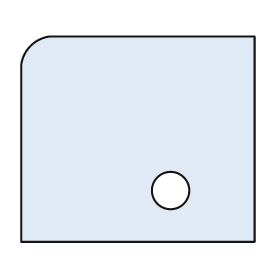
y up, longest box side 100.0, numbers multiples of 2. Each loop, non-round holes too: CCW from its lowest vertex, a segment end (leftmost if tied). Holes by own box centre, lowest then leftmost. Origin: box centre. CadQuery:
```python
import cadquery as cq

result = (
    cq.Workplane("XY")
    .moveTo(-50.0, -44.0)
    .lineTo(50.0, -44.0)
    .lineTo(50.0, 44.0)
    .lineTo(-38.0, 44.0)
    .threePointArc((-46.0, 40.0), (-50.0, 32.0))
    .close()
    .moveTo(14.0, -22.0)
    .circle(8.0)
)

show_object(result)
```